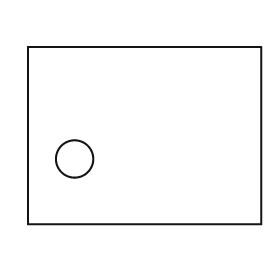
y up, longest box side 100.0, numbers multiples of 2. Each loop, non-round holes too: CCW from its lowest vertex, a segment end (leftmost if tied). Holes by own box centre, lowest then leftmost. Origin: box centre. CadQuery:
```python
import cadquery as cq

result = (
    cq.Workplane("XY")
    .moveTo(-50.0, -38.0)
    .lineTo(50.0, -38.0)
    .lineTo(50.0, 38.0)
    .lineTo(-50.0, 38.0)
    .close()
    .moveTo(-30.0, -10.0)
    .circle(8.0)
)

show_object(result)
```